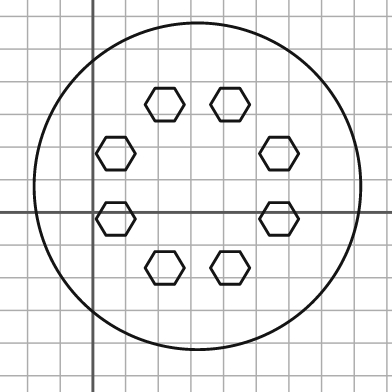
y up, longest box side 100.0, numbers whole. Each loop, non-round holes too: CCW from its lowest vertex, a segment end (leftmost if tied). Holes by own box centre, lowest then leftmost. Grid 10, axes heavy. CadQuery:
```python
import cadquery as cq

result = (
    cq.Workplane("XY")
    .moveTo(32.0, 8.0)
    .circle(50.0)
    .moveTo(19.0, -22.0)
    .lineTo(25.0, -22.0)
    .lineTo(28.0, -17.0)
    .lineTo(25.0, -12.0)
    .lineTo(19.0, -12.0)
    .lineTo(16.0, -17.0)
    .close()
    .moveTo(39.0, -22.0)
    .lineTo(45.0, -22.0)
    .lineTo(48.0, -17.0)
    .lineTo(45.0, -12.0)
    .lineTo(39.0, -12.0)
    .lineTo(36.0, -17.0)
    .close()
    .moveTo(4.0, -7.0)
    .lineTo(10.0, -7.0)
    .lineTo(13.0, -2.0)
    .lineTo(10.0, 3.0)
    .lineTo(4.0, 3.0)
    .lineTo(1.0, -2.0)
    .close()
    .moveTo(54.0, -7.0)
    .lineTo(60.0, -7.0)
    .lineTo(63.0, -2.0)
    .lineTo(60.0, 3.0)
    .lineTo(54.0, 3.0)
    .lineTo(51.0, -2.0)
    .close()
    .moveTo(4.0, 13.0)
    .lineTo(10.0, 13.0)
    .lineTo(13.0, 18.0)
    .lineTo(10.0, 23.0)
    .lineTo(4.0, 23.0)
    .lineTo(1.0, 18.0)
    .close()
    .moveTo(54.0, 13.0)
    .lineTo(60.0, 13.0)
    .lineTo(63.0, 18.0)
    .lineTo(60.0, 23.0)
    .lineTo(54.0, 23.0)
    .lineTo(51.0, 18.0)
    .close()
    .moveTo(19.0, 28.0)
    .lineTo(25.0, 28.0)
    .lineTo(28.0, 33.0)
    .lineTo(25.0, 38.0)
    .lineTo(19.0, 38.0)
    .lineTo(16.0, 33.0)
    .close()
    .moveTo(39.0, 28.0)
    .lineTo(45.0, 28.0)
    .lineTo(48.0, 33.0)
    .lineTo(45.0, 38.0)
    .lineTo(39.0, 38.0)
    .lineTo(36.0, 33.0)
    .close()
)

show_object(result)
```